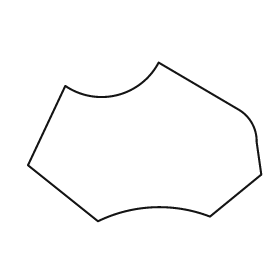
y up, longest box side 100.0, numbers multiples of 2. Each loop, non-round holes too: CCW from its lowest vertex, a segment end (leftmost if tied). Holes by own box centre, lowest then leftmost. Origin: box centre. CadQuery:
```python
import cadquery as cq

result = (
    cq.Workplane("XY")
    .moveTo(-20.0, -34.0)
    .threePointArc((4.0, -28.0), (28.0, -32.0))
    .lineTo(50.0, -14.0)
    .lineTo(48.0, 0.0)
    .threePointArc((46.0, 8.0), (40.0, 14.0))
    .lineTo(6.0, 34.0)
    .threePointArc((-12.0, 20.0), (-34.0, 24.0))
    .lineTo(-50.0, -10.0)
    .close()
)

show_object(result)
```